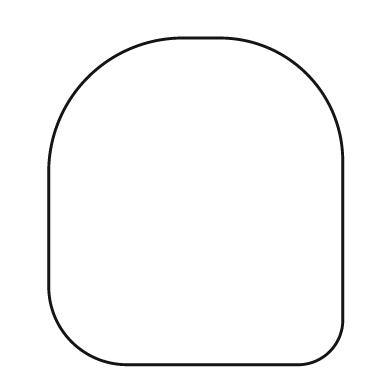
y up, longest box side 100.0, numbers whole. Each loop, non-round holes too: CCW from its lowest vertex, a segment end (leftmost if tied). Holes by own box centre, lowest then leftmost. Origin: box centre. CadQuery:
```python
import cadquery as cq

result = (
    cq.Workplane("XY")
    .moveTo(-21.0, -50.0)
    .lineTo(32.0, -50.0)
    .threePointArc((41.0, -46.0), (45.0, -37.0))
    .lineTo(45.0, 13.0)
    .threePointArc((34.0, 39.0), (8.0, 50.0))
    .lineTo(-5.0, 50.0)
    .threePointArc((-33.0, 38.0), (-45.0, 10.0))
    .lineTo(-45.0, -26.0)
    .threePointArc((-38.0, -43.0), (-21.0, -50.0))
    .close()
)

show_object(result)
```